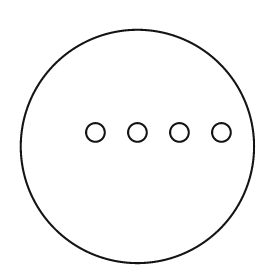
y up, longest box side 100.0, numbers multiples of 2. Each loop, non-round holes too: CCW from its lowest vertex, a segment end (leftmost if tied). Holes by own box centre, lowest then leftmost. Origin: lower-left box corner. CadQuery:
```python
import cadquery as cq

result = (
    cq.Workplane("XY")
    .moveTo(50.0, 50.0)
    .circle(50.0)
    .moveTo(32.0, 56.0)
    .circle(4.0)
    .moveTo(50.0, 56.0)
    .circle(4.0)
    .moveTo(68.0, 56.0)
    .circle(4.0)
    .moveTo(86.0, 56.0)
    .circle(4.0)
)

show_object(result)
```